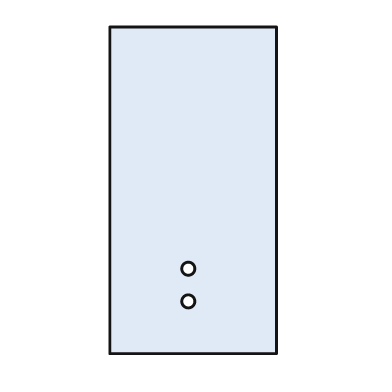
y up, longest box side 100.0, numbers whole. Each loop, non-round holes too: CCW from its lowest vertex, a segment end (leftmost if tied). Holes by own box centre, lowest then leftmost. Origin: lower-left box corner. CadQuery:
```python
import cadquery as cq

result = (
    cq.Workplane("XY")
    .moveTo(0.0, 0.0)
    .lineTo(51.0, 0.0)
    .lineTo(51.0, 100.0)
    .lineTo(0.0, 100.0)
    .close()
    .moveTo(24.0, 16.0)
    .circle(2.0)
    .moveTo(24.0, 26.0)
    .circle(2.0)
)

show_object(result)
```